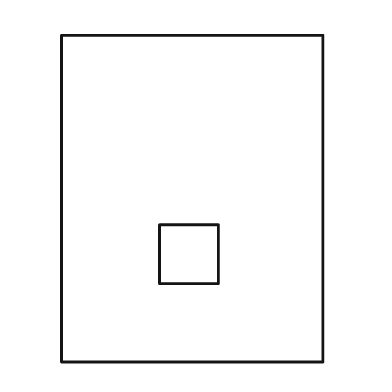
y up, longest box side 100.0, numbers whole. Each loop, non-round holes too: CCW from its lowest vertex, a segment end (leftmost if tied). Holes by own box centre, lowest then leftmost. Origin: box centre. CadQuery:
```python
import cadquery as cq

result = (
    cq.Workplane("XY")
    .moveTo(-40.0, -50.0)
    .lineTo(40.0, -50.0)
    .lineTo(40.0, 50.0)
    .lineTo(-40.0, 50.0)
    .close()
    .moveTo(-10.0, -26.0)
    .lineTo(8.0, -26.0)
    .lineTo(8.0, -8.0)
    .lineTo(-10.0, -8.0)
    .close()
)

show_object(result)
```